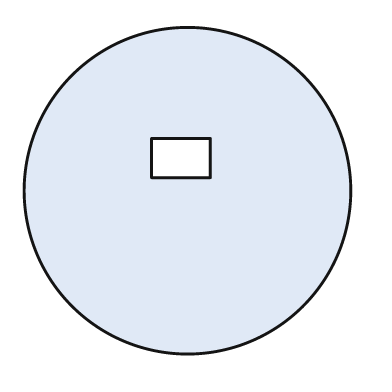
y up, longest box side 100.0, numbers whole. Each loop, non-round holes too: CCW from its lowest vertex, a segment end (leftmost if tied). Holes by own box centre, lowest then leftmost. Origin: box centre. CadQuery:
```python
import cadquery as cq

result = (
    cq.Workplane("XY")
    .moveTo(0.0, 0.0)
    .circle(50.0)
    .moveTo(-11.0, 4.0)
    .lineTo(7.0, 4.0)
    .lineTo(7.0, 16.0)
    .lineTo(-11.0, 16.0)
    .close()
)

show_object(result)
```